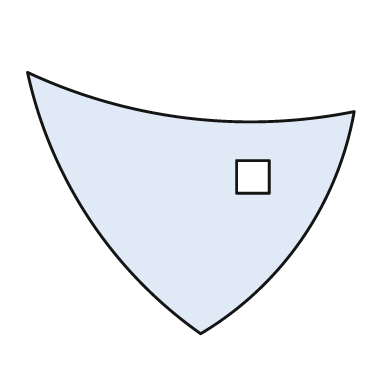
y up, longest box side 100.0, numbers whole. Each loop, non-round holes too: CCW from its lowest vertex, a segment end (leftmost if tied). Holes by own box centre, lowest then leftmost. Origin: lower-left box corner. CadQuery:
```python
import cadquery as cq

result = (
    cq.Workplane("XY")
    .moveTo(53.0, 0.0)
    .threePointArc((84.0, 29.0), (100.0, 68.0))
    .threePointArc((49.0, 66.0), (0.0, 80.0))
    .threePointArc((19.0, 35.0), (53.0, 0.0))
    .close()
    .moveTo(64.0, 43.0)
    .lineTo(74.0, 43.0)
    .lineTo(74.0, 53.0)
    .lineTo(64.0, 53.0)
    .close()
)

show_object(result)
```